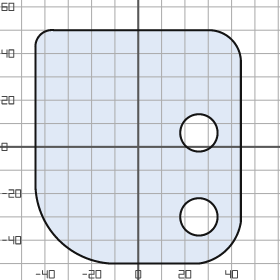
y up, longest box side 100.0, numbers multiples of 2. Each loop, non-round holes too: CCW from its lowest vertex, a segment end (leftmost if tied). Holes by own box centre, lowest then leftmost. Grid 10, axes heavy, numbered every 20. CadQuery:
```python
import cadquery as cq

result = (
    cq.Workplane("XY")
    .moveTo(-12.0, -50.0)
    .lineTo(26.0, -50.0)
    .threePointArc((38.0, -44.0), (44.0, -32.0))
    .lineTo(44.0, 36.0)
    .threePointArc((40.0, 46.0), (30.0, 50.0))
    .lineTo(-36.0, 50.0)
    .threePointArc((-42.0, 48.0), (-44.0, 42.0))
    .lineTo(-44.0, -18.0)
    .threePointArc((-34.0, -40.0), (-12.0, -50.0))
    .close()
    .moveTo(26.0, -30.0)
    .circle(8.0)
    .moveTo(26.0, 6.0)
    .circle(8.0)
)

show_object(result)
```